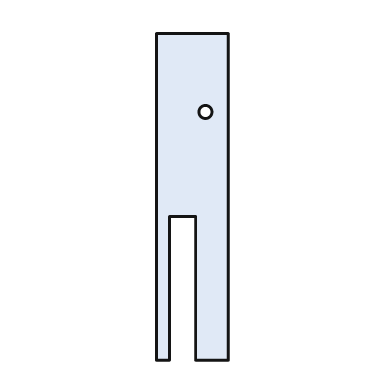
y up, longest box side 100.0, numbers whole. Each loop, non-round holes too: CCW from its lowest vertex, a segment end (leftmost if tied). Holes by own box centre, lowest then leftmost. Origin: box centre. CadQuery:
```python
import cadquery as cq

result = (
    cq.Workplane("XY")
    .moveTo(-11.0, -50.0)
    .lineTo(-7.0, -50.0)
    .lineTo(-7.0, -6.0)
    .lineTo(1.0, -6.0)
    .lineTo(1.0, -50.0)
    .lineTo(11.0, -50.0)
    .lineTo(11.0, 50.0)
    .lineTo(-11.0, 50.0)
    .close()
    .moveTo(4.0, 26.0)
    .circle(2.0)
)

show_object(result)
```